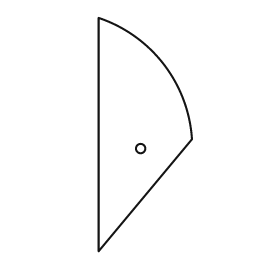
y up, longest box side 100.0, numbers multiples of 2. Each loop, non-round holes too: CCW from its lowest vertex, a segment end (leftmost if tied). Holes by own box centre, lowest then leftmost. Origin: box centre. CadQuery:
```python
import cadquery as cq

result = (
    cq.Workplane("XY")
    .moveTo(-20.0, -50.0)
    .lineTo(20.0, -2.0)
    .threePointArc((8.0, 30.0), (-20.0, 50.0))
    .close()
    .moveTo(-2.0, -6.0)
    .circle(2.0)
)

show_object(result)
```